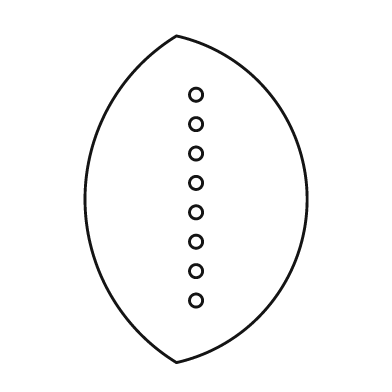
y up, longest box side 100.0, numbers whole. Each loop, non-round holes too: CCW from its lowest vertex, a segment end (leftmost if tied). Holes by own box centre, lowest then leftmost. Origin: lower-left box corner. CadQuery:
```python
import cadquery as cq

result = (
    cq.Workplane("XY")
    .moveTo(28.0, 0.0)
    .threePointArc((68.0, 50.0), (28.0, 100.0))
    .threePointArc((0.0, 50.0), (28.0, 0.0))
    .close()
    .moveTo(34.0, 19.0)
    .circle(2.0)
    .moveTo(34.0, 28.0)
    .circle(2.0)
    .moveTo(34.0, 37.0)
    .circle(2.0)
    .moveTo(34.0, 46.0)
    .circle(2.0)
    .moveTo(34.0, 55.0)
    .circle(2.0)
    .moveTo(34.0, 64.0)
    .circle(2.0)
    .moveTo(34.0, 73.0)
    .circle(2.0)
    .moveTo(34.0, 82.0)
    .circle(2.0)
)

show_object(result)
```